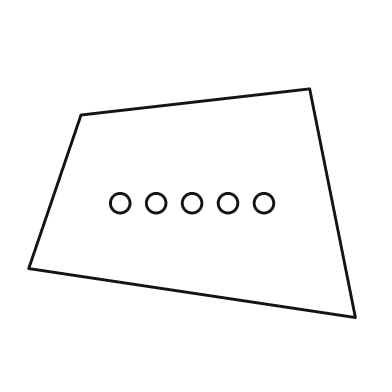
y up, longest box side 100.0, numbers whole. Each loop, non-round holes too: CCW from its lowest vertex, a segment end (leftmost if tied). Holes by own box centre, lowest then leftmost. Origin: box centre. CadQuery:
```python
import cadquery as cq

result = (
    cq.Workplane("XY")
    .moveTo(50.0, -35.0)
    .lineTo(36.0, 35.0)
    .lineTo(-34.0, 27.0)
    .lineTo(-50.0, -20.0)
    .close()
    .moveTo(-22.0, 0.0)
    .circle(3.0)
    .moveTo(-11.0, 0.0)
    .circle(3.0)
    .moveTo(0.0, 0.0)
    .circle(3.0)
    .moveTo(11.0, 0.0)
    .circle(3.0)
    .moveTo(22.0, 0.0)
    .circle(3.0)
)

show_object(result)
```